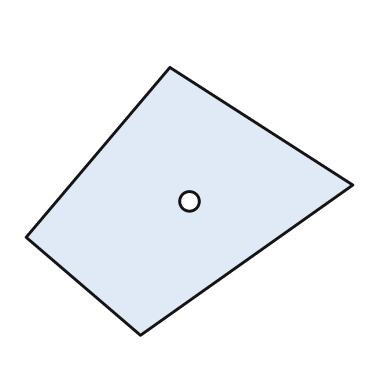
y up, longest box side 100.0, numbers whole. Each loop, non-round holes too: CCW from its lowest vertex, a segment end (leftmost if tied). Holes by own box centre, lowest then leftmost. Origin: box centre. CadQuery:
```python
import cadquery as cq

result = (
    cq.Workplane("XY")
    .moveTo(-15.0, -41.0)
    .lineTo(50.0, 5.0)
    .lineTo(-6.0, 41.0)
    .lineTo(-50.0, -11.0)
    .close()
    .moveTo(0.0, 0.0)
    .circle(3.0)
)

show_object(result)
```